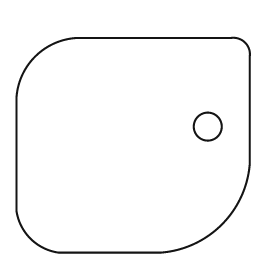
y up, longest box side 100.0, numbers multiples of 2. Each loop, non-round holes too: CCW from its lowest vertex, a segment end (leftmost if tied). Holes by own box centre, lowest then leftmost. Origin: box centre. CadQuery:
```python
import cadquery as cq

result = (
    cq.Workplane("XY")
    .moveTo(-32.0, -46.0)
    .lineTo(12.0, -46.0)
    .threePointArc((38.0, -34.0), (50.0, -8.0))
    .lineTo(50.0, 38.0)
    .threePointArc((48.0, 44.0), (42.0, 46.0))
    .lineTo(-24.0, 46.0)
    .threePointArc((-42.0, 38.0), (-50.0, 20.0))
    .lineTo(-50.0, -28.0)
    .threePointArc((-44.0, -40.0), (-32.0, -46.0))
    .close()
    .moveTo(32.0, 8.0)
    .circle(6.0)
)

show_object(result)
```